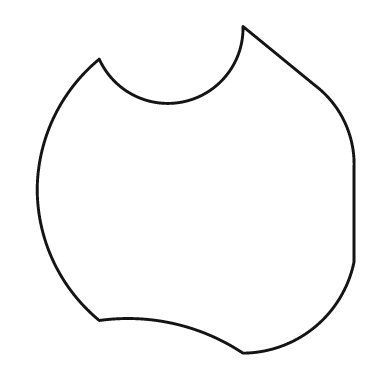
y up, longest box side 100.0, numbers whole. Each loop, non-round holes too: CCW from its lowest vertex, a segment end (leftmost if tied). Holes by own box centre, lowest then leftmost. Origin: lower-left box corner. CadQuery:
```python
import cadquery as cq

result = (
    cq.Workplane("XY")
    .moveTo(63.0, 0.0)
    .threePointArc((85.0, 8.0), (97.0, 28.0))
    .lineTo(97.0, 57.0)
    .threePointArc((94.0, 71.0), (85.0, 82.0))
    .lineTo(63.0, 100.0)
    .threePointArc((45.0, 77.0), (19.0, 90.0))
    .threePointArc((5.0, 72.0), (0.0, 50.0))
    .threePointArc((5.0, 28.0), (19.0, 10.0))
    .threePointArc((42.0, 9.0), (63.0, 0.0))
    .close()
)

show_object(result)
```